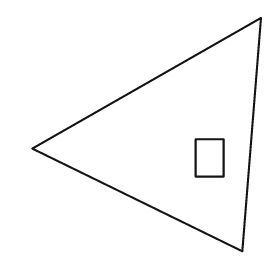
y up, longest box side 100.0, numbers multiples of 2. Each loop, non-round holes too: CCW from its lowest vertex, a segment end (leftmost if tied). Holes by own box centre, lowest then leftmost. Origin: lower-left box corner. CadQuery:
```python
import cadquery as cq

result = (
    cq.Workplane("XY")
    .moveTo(90.0, 0.0)
    .lineTo(98.0, 100.0)
    .lineTo(0.0, 44.0)
    .close()
    .moveTo(70.0, 32.0)
    .lineTo(82.0, 32.0)
    .lineTo(82.0, 48.0)
    .lineTo(70.0, 48.0)
    .close()
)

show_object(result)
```